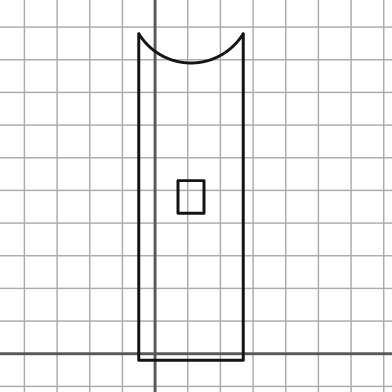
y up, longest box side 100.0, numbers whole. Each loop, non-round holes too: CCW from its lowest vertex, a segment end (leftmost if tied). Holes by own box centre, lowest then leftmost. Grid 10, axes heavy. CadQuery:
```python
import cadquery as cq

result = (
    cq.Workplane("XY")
    .moveTo(-5.0, -2.0)
    .lineTo(27.0, -2.0)
    .lineTo(27.0, 98.0)
    .threePointArc((11.0, 89.0), (-5.0, 98.0))
    .close()
    .moveTo(7.0, 43.0)
    .lineTo(15.0, 43.0)
    .lineTo(15.0, 53.0)
    .lineTo(7.0, 53.0)
    .close()
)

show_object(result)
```